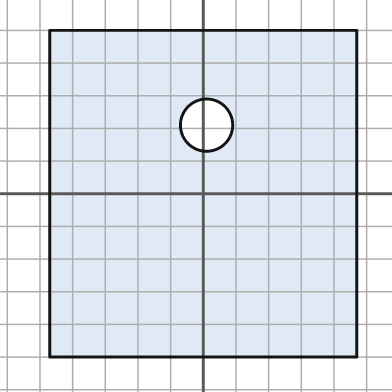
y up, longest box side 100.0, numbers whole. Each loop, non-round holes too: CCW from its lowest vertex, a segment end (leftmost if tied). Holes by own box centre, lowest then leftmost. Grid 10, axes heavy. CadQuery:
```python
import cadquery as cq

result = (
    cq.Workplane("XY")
    .moveTo(-47.0, -50.0)
    .lineTo(47.0, -50.0)
    .lineTo(47.0, 50.0)
    .lineTo(-47.0, 50.0)
    .close()
    .moveTo(1.0, 21.0)
    .circle(8.0)
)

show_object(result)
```